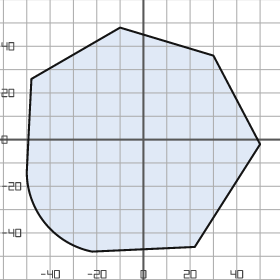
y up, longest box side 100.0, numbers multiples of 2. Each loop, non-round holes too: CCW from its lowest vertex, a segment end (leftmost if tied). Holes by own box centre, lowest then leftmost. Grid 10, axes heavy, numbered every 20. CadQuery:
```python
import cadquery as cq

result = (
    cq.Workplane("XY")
    .moveTo(-22.0, -48.0)
    .lineTo(22.0, -46.0)
    .lineTo(50.0, -2.0)
    .lineTo(30.0, 36.0)
    .lineTo(-10.0, 48.0)
    .lineTo(-48.0, 26.0)
    .lineTo(-50.0, -14.0)
    .threePointArc((-42.0, -36.0), (-22.0, -48.0))
    .close()
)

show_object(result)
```